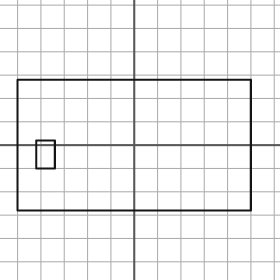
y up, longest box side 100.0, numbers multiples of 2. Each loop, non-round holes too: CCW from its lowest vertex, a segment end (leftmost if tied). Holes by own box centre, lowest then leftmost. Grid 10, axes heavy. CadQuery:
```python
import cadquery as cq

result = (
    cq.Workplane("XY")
    .moveTo(-50.0, -28.0)
    .lineTo(50.0, -28.0)
    .lineTo(50.0, 28.0)
    .lineTo(-50.0, 28.0)
    .close()
    .moveTo(-42.0, -10.0)
    .lineTo(-34.0, -10.0)
    .lineTo(-34.0, 2.0)
    .lineTo(-42.0, 2.0)
    .close()
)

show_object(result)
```